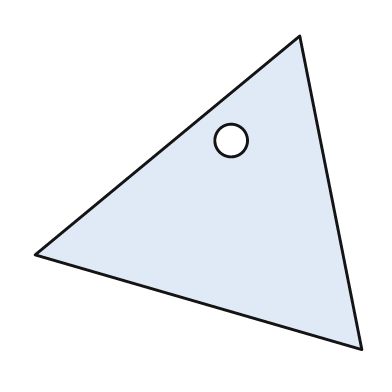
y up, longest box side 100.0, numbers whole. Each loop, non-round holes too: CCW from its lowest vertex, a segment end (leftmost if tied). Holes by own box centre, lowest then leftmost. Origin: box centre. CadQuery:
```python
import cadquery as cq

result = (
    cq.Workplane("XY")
    .moveTo(50.0, -48.0)
    .lineTo(31.0, 48.0)
    .lineTo(-50.0, -19.0)
    .close()
    .moveTo(10.0, 16.0)
    .circle(5.0)
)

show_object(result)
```